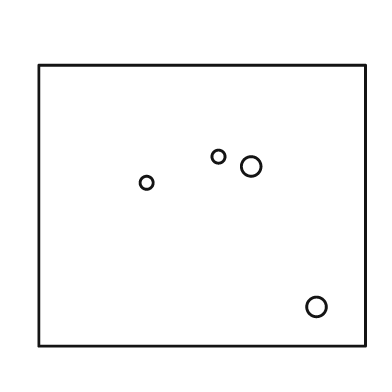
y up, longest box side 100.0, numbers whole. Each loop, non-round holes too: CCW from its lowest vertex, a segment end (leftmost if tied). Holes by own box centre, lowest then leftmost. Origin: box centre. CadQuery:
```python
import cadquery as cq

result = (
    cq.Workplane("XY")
    .moveTo(-50.0, -43.0)
    .lineTo(50.0, -43.0)
    .lineTo(50.0, 43.0)
    .lineTo(-50.0, 43.0)
    .close()
    .moveTo(35.0, -31.0)
    .circle(3.0)
    .moveTo(-17.0, 7.0)
    .circle(2.0)
    .moveTo(15.0, 12.0)
    .circle(3.0)
    .moveTo(5.0, 15.0)
    .circle(2.0)
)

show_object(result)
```